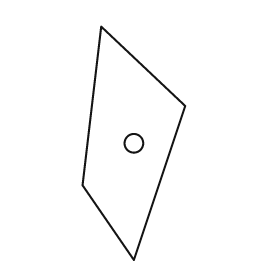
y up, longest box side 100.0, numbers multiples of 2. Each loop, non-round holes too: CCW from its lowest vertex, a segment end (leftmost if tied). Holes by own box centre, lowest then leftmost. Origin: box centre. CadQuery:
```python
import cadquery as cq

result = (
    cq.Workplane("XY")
    .moveTo(0.0, -50.0)
    .lineTo(22.0, 16.0)
    .lineTo(-14.0, 50.0)
    .lineTo(-22.0, -18.0)
    .close()
    .moveTo(0.0, 0.0)
    .circle(4.0)
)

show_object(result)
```